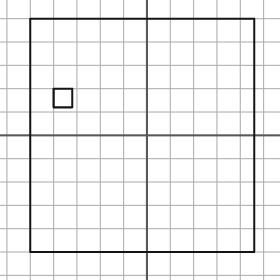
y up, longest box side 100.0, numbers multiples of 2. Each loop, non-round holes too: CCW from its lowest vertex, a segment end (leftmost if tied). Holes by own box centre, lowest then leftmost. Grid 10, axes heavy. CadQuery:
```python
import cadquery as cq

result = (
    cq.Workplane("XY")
    .moveTo(-50.0, -50.0)
    .lineTo(46.0, -50.0)
    .lineTo(46.0, 50.0)
    .lineTo(-50.0, 50.0)
    .close()
    .moveTo(-40.0, 12.0)
    .lineTo(-32.0, 12.0)
    .lineTo(-32.0, 20.0)
    .lineTo(-40.0, 20.0)
    .close()
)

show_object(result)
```